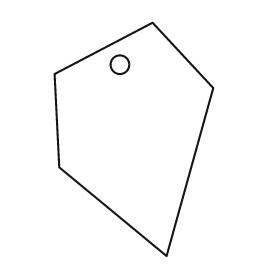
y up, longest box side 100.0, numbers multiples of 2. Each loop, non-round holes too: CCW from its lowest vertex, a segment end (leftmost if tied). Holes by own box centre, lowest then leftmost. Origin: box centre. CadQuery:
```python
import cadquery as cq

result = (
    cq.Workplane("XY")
    .moveTo(14.0, -50.0)
    .lineTo(34.0, 22.0)
    .lineTo(8.0, 50.0)
    .lineTo(-34.0, 28.0)
    .lineTo(-32.0, -12.0)
    .close()
    .moveTo(-6.0, 32.0)
    .circle(4.0)
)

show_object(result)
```